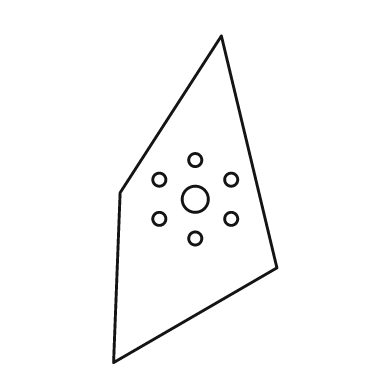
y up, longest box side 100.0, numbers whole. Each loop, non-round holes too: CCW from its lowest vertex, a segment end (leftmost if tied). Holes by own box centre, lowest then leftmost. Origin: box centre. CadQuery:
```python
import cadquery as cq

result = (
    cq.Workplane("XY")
    .moveTo(-25.0, -50.0)
    .lineTo(25.0, -21.0)
    .lineTo(8.0, 50.0)
    .lineTo(-23.0, 2.0)
    .close()
    .moveTo(0.0, -12.0)
    .circle(2.0)
    .moveTo(-11.0, -6.0)
    .circle(2.0)
    .moveTo(11.0, -6.0)
    .circle(2.0)
    .moveTo(0.0, 0.0)
    .circle(4.0)
    .moveTo(-11.0, 6.0)
    .circle(2.0)
    .moveTo(11.0, 6.0)
    .circle(2.0)
    .moveTo(0.0, 12.0)
    .circle(2.0)
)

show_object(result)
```